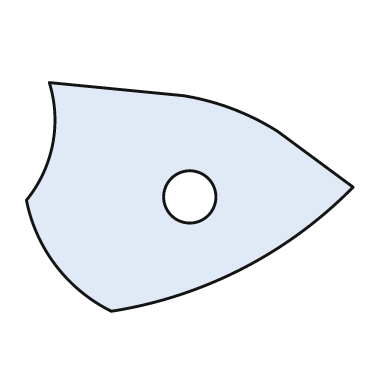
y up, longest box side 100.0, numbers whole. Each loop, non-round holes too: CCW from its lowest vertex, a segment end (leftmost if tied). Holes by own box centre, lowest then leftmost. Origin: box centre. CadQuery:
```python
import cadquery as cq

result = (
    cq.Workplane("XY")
    .moveTo(-24.0, -35.0)
    .threePointArc((16.0, -22.0), (50.0, 3.0))
    .lineTo(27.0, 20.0)
    .threePointArc((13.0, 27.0), (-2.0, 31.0))
    .lineTo(-43.0, 35.0)
    .threePointArc((-42.0, 16.0), (-50.0, -1.0))
    .threePointArc((-41.0, -21.0), (-24.0, -35.0))
    .close()
    .moveTo(0.0, 0.0)
    .circle(8.0)
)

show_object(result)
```